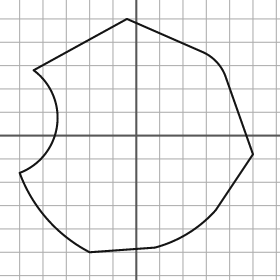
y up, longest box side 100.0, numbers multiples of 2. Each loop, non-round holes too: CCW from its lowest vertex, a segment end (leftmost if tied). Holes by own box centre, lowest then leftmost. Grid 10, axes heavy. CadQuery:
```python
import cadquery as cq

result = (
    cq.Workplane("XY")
    .moveTo(-20.0, -50.0)
    .lineTo(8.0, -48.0)
    .threePointArc((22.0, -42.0), (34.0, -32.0))
    .lineTo(50.0, -8.0)
    .lineTo(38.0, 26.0)
    .threePointArc((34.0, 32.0), (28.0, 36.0))
    .lineTo(-4.0, 50.0)
    .lineTo(-44.0, 28.0)
    .threePointArc((-34.0, 4.0), (-50.0, -16.0))
    .threePointArc((-38.0, -36.0), (-20.0, -50.0))
    .close()
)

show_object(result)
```